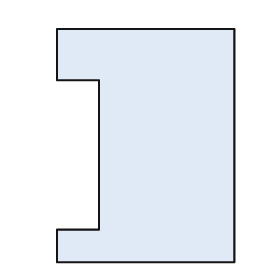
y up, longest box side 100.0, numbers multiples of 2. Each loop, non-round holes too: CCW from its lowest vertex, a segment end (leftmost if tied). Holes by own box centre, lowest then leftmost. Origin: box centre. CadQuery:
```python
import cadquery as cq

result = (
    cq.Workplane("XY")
    .moveTo(-38.0, -50.0)
    .lineTo(38.0, -50.0)
    .lineTo(38.0, 50.0)
    .lineTo(-38.0, 50.0)
    .lineTo(-38.0, 28.0)
    .lineTo(-20.0, 28.0)
    .lineTo(-20.0, -36.0)
    .lineTo(-38.0, -36.0)
    .close()
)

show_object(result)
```